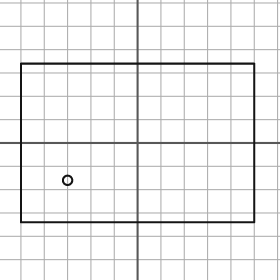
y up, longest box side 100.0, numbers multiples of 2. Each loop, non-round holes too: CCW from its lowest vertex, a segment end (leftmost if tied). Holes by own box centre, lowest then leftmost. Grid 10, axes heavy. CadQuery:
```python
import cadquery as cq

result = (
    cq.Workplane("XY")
    .moveTo(-50.0, -34.0)
    .lineTo(50.0, -34.0)
    .lineTo(50.0, 34.0)
    .lineTo(-50.0, 34.0)
    .close()
    .moveTo(-30.0, -16.0)
    .circle(2.0)
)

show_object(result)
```